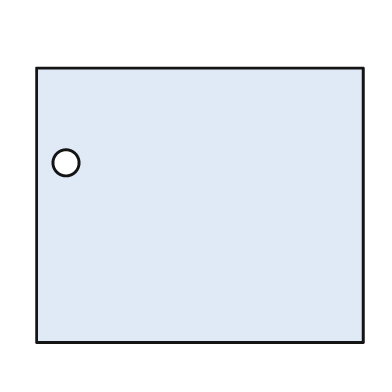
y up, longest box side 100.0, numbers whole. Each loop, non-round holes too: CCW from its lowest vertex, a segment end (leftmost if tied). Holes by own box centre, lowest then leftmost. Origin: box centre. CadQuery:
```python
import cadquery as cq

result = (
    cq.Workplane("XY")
    .moveTo(-50.0, -42.0)
    .lineTo(50.0, -42.0)
    .lineTo(50.0, 42.0)
    .lineTo(-50.0, 42.0)
    .close()
    .moveTo(-41.0, 13.0)
    .circle(4.0)
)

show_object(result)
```